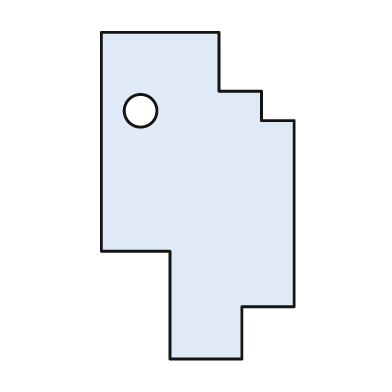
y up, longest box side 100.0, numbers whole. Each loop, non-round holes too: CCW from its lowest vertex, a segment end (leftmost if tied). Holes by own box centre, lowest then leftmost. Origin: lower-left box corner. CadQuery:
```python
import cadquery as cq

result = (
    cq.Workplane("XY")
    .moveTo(21.0, 0.0)
    .lineTo(43.0, 0.0)
    .lineTo(43.0, 16.0)
    .lineTo(59.0, 16.0)
    .lineTo(59.0, 73.0)
    .lineTo(49.0, 73.0)
    .lineTo(49.0, 82.0)
    .lineTo(36.0, 82.0)
    .lineTo(36.0, 100.0)
    .lineTo(0.0, 100.0)
    .lineTo(0.0, 33.0)
    .lineTo(21.0, 33.0)
    .close()
    .moveTo(12.0, 76.0)
    .circle(5.0)
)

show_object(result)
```